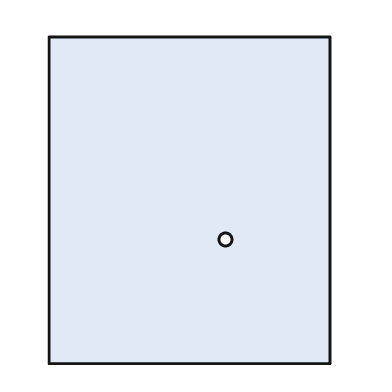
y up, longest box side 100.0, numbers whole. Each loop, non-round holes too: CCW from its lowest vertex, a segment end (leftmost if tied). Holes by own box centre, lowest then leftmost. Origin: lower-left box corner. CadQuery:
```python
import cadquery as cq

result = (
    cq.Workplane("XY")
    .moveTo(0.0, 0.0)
    .lineTo(86.0, 0.0)
    .lineTo(86.0, 100.0)
    .lineTo(0.0, 100.0)
    .close()
    .moveTo(54.0, 38.0)
    .circle(2.0)
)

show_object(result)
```